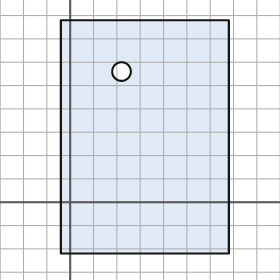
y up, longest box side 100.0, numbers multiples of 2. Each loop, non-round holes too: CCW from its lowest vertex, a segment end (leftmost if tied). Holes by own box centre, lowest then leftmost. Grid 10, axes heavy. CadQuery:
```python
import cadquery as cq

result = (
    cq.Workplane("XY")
    .moveTo(-4.0, -22.0)
    .lineTo(68.0, -22.0)
    .lineTo(68.0, 78.0)
    .lineTo(-4.0, 78.0)
    .close()
    .moveTo(22.0, 56.0)
    .circle(4.0)
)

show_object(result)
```